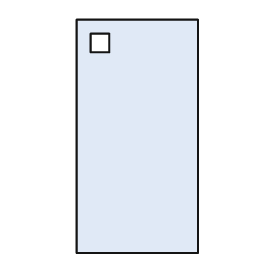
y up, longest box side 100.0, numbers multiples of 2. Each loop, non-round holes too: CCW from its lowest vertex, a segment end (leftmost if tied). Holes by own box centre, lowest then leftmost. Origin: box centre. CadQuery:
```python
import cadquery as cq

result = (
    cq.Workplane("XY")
    .moveTo(-26.0, -50.0)
    .lineTo(26.0, -50.0)
    .lineTo(26.0, 50.0)
    .lineTo(-26.0, 50.0)
    .close()
    .moveTo(-20.0, 36.0)
    .lineTo(-12.0, 36.0)
    .lineTo(-12.0, 44.0)
    .lineTo(-20.0, 44.0)
    .close()
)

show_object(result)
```